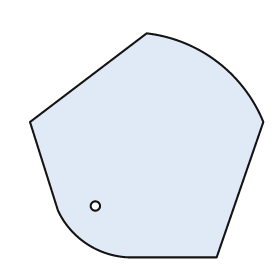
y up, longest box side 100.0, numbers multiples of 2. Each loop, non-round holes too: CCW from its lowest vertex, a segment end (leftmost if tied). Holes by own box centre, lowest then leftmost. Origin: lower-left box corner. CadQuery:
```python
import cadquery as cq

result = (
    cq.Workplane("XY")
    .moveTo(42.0, 0.0)
    .lineTo(80.0, 0.0)
    .lineTo(100.0, 58.0)
    .threePointArc((80.0, 84.0), (50.0, 96.0))
    .lineTo(0.0, 58.0)
    .lineTo(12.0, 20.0)
    .threePointArc((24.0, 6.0), (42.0, 0.0))
    .close()
    .moveTo(28.0, 22.0)
    .circle(2.0)
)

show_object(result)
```